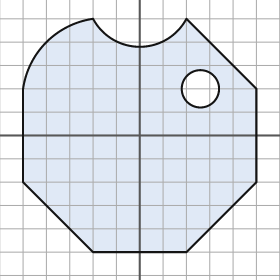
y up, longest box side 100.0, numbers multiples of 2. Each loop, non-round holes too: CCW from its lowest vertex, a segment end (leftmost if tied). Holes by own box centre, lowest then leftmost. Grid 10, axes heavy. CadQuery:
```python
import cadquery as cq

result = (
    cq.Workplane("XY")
    .moveTo(-20.0, -50.0)
    .lineTo(20.0, -50.0)
    .lineTo(50.0, -20.0)
    .lineTo(50.0, 20.0)
    .lineTo(20.0, 50.0)
    .threePointArc((0.0, 38.0), (-20.0, 50.0))
    .threePointArc((-40.0, 40.0), (-50.0, 20.0))
    .lineTo(-50.0, -20.0)
    .close()
    .moveTo(26.0, 20.0)
    .circle(8.0)
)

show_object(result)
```